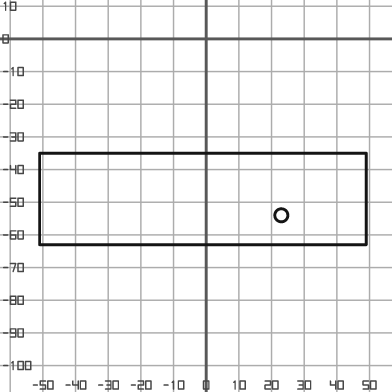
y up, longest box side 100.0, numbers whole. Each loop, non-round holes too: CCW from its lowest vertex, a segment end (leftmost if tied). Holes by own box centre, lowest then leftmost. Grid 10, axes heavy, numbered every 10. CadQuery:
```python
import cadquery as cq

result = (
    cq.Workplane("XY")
    .moveTo(-51.0, -63.0)
    .lineTo(49.0, -63.0)
    .lineTo(49.0, -35.0)
    .lineTo(-51.0, -35.0)
    .close()
    .moveTo(23.0, -54.0)
    .circle(2.0)
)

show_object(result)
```